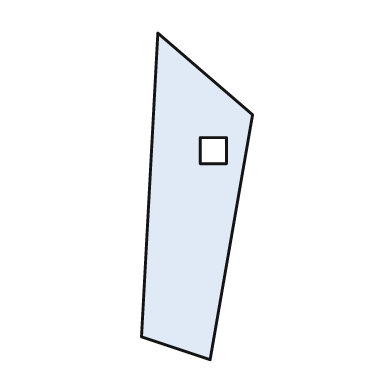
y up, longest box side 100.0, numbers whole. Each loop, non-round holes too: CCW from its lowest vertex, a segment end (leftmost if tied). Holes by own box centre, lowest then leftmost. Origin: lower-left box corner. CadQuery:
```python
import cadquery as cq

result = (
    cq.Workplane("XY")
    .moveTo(21.0, 0.0)
    .lineTo(34.0, 75.0)
    .lineTo(5.0, 100.0)
    .lineTo(0.0, 7.0)
    .close()
    .moveTo(18.0, 60.0)
    .lineTo(26.0, 60.0)
    .lineTo(26.0, 68.0)
    .lineTo(18.0, 68.0)
    .close()
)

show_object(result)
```